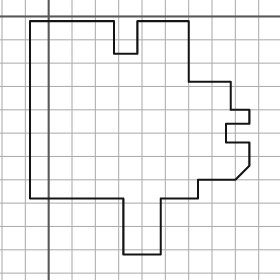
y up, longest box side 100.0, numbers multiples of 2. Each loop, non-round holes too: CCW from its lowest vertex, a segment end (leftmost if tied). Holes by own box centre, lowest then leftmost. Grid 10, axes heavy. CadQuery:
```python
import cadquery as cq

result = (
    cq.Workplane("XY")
    .moveTo(32.0, -102.0)
    .lineTo(48.0, -102.0)
    .lineTo(48.0, -78.0)
    .lineTo(64.0, -78.0)
    .lineTo(64.0, -70.0)
    .lineTo(80.0, -70.0)
    .lineTo(86.0, -64.0)
    .lineTo(86.0, -54.0)
    .lineTo(76.0, -54.0)
    .lineTo(76.0, -46.0)
    .lineTo(86.0, -46.0)
    .lineTo(86.0, -40.0)
    .lineTo(78.0, -40.0)
    .lineTo(78.0, -28.0)
    .lineTo(60.0, -28.0)
    .lineTo(60.0, -2.0)
    .lineTo(38.0, -2.0)
    .lineTo(38.0, -16.0)
    .lineTo(28.0, -16.0)
    .lineTo(28.0, -2.0)
    .lineTo(-8.0, -2.0)
    .lineTo(-8.0, -78.0)
    .lineTo(32.0, -78.0)
    .close()
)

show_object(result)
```